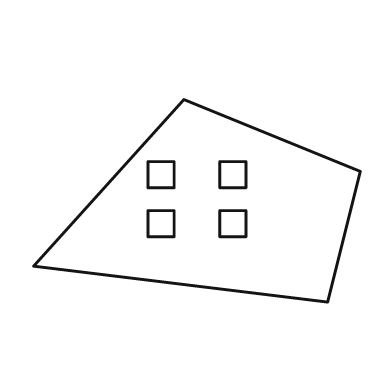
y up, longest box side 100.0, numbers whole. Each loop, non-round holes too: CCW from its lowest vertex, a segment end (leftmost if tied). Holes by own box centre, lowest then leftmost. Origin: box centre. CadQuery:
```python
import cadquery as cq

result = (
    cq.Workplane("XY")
    .moveTo(40.0, -31.0)
    .lineTo(50.0, 9.0)
    .lineTo(-4.0, 31.0)
    .lineTo(-50.0, -20.0)
    .close()
    .moveTo(-15.0, -11.0)
    .lineTo(-7.0, -11.0)
    .lineTo(-7.0, -3.0)
    .lineTo(-15.0, -3.0)
    .close()
    .moveTo(7.0, -11.0)
    .lineTo(15.0, -11.0)
    .lineTo(15.0, -3.0)
    .lineTo(7.0, -3.0)
    .close()
    .moveTo(-15.0, 4.0)
    .lineTo(-7.0, 4.0)
    .lineTo(-7.0, 12.0)
    .lineTo(-15.0, 12.0)
    .close()
    .moveTo(7.0, 4.0)
    .lineTo(15.0, 4.0)
    .lineTo(15.0, 12.0)
    .lineTo(7.0, 12.0)
    .close()
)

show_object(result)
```